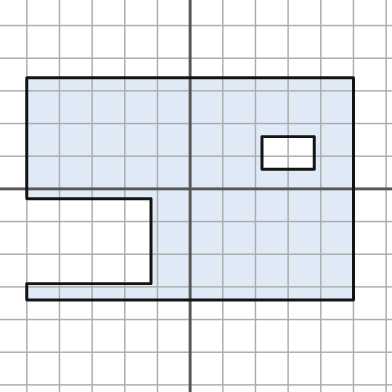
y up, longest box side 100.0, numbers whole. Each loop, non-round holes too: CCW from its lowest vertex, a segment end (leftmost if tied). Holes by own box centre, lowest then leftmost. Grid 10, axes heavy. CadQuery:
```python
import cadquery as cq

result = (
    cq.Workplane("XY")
    .moveTo(-50.0, -34.0)
    .lineTo(50.0, -34.0)
    .lineTo(50.0, 34.0)
    .lineTo(-50.0, 34.0)
    .lineTo(-50.0, -3.0)
    .lineTo(-12.0, -3.0)
    .lineTo(-12.0, -29.0)
    .lineTo(-50.0, -29.0)
    .close()
    .moveTo(22.0, 6.0)
    .lineTo(38.0, 6.0)
    .lineTo(38.0, 16.0)
    .lineTo(22.0, 16.0)
    .close()
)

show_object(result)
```